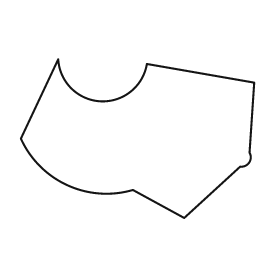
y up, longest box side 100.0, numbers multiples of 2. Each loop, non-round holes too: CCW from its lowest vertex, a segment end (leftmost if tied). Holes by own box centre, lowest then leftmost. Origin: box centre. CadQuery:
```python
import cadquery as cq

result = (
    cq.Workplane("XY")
    .moveTo(20.0, -34.0)
    .lineTo(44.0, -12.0)
    .threePointArc((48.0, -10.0), (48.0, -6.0))
    .lineTo(50.0, 24.0)
    .lineTo(4.0, 32.0)
    .threePointArc((-16.0, 16.0), (-34.0, 34.0))
    .lineTo(-50.0, 0.0)
    .threePointArc((-30.0, -20.0), (-2.0, -22.0))
    .close()
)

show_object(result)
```